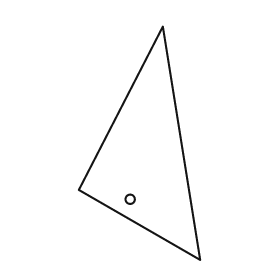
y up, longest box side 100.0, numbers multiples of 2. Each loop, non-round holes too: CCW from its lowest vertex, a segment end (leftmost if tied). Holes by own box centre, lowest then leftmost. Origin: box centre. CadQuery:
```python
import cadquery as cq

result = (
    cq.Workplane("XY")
    .moveTo(26.0, -50.0)
    .lineTo(10.0, 50.0)
    .lineTo(-26.0, -20.0)
    .close()
    .moveTo(-4.0, -24.0)
    .circle(2.0)
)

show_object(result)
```